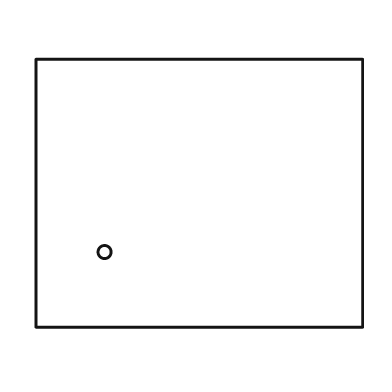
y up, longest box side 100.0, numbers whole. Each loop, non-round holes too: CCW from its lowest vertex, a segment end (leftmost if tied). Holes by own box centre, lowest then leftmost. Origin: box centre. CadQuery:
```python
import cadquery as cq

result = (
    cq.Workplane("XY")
    .moveTo(-50.0, -41.0)
    .lineTo(50.0, -41.0)
    .lineTo(50.0, 41.0)
    .lineTo(-50.0, 41.0)
    .close()
    .moveTo(-29.0, -18.0)
    .circle(2.0)
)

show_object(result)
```